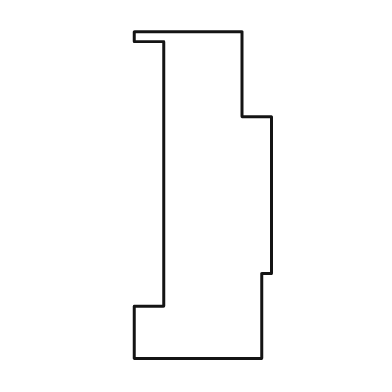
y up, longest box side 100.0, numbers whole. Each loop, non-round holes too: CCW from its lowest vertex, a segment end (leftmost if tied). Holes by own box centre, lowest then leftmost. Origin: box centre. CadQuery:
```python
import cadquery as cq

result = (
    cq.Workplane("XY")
    .moveTo(-21.0, -50.0)
    .lineTo(18.0, -50.0)
    .lineTo(18.0, -24.0)
    .lineTo(21.0, -24.0)
    .lineTo(21.0, 24.0)
    .lineTo(12.0, 24.0)
    .lineTo(12.0, 50.0)
    .lineTo(-21.0, 50.0)
    .lineTo(-21.0, 47.0)
    .lineTo(-12.0, 47.0)
    .lineTo(-12.0, -34.0)
    .lineTo(-21.0, -34.0)
    .close()
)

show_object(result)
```